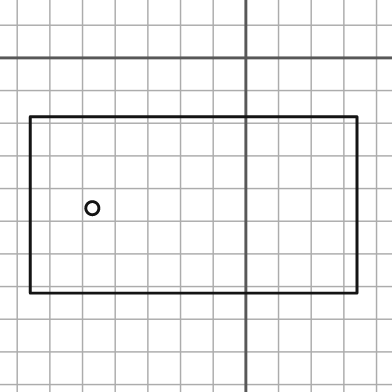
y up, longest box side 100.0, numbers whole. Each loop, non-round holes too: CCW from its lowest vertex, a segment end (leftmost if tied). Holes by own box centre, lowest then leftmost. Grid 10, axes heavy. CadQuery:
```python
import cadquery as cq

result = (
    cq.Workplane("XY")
    .moveTo(-66.0, -72.0)
    .lineTo(34.0, -72.0)
    .lineTo(34.0, -18.0)
    .lineTo(-66.0, -18.0)
    .close()
    .moveTo(-47.0, -46.0)
    .circle(2.0)
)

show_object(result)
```